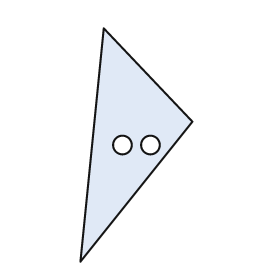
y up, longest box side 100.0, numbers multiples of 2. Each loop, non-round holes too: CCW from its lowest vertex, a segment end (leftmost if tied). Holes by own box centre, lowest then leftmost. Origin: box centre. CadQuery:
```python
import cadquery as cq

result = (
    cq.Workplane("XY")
    .moveTo(-24.0, -50.0)
    .lineTo(24.0, 10.0)
    .lineTo(-14.0, 50.0)
    .close()
    .moveTo(-6.0, 0.0)
    .circle(4.0)
    .moveTo(6.0, 0.0)
    .circle(4.0)
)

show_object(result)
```